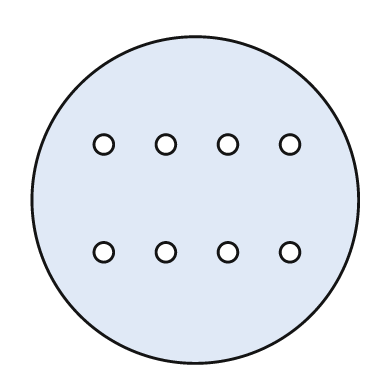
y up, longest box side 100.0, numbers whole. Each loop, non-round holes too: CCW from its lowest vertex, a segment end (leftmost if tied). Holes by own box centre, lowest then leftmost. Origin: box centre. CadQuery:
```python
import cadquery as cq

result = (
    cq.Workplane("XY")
    .moveTo(0.0, 0.0)
    .circle(50.0)
    .moveTo(-28.0, -16.0)
    .circle(3.0)
    .moveTo(-9.0, -16.0)
    .circle(3.0)
    .moveTo(10.0, -16.0)
    .circle(3.0)
    .moveTo(29.0, -16.0)
    .circle(3.0)
    .moveTo(-28.0, 17.0)
    .circle(3.0)
    .moveTo(-9.0, 17.0)
    .circle(3.0)
    .moveTo(10.0, 17.0)
    .circle(3.0)
    .moveTo(29.0, 17.0)
    .circle(3.0)
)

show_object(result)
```